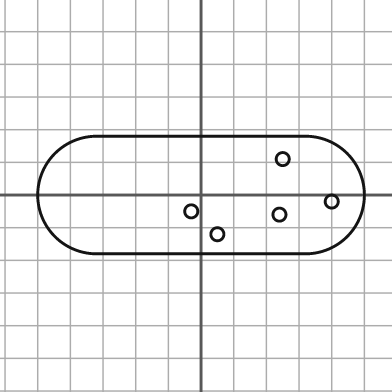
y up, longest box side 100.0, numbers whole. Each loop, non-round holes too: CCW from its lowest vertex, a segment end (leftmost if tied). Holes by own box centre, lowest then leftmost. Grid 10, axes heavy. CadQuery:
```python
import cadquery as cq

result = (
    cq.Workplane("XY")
    .moveTo(-32.0, -18.0)
    .lineTo(32.0, -18.0)
    .threePointArc((50.0, 0.0), (32.0, 18.0))
    .lineTo(-32.0, 18.0)
    .threePointArc((-50.0, 0.0), (-32.0, -18.0))
    .close()
    .moveTo(5.0, -12.0)
    .circle(2.0)
    .moveTo(24.0, -6.0)
    .circle(2.0)
    .moveTo(-3.0, -5.0)
    .circle(2.0)
    .moveTo(40.0, -2.0)
    .circle(2.0)
    .moveTo(25.0, 11.0)
    .circle(2.0)
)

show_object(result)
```